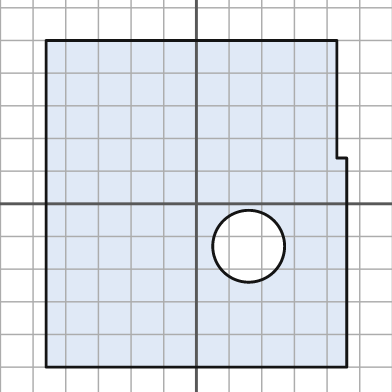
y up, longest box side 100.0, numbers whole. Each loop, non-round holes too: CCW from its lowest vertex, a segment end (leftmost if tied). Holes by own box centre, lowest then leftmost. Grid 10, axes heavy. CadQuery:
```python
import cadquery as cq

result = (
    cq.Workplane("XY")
    .moveTo(-46.0, -50.0)
    .lineTo(46.0, -50.0)
    .lineTo(46.0, 14.0)
    .lineTo(43.0, 14.0)
    .lineTo(43.0, 50.0)
    .lineTo(-46.0, 50.0)
    .close()
    .moveTo(16.0, -13.0)
    .circle(11.0)
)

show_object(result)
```